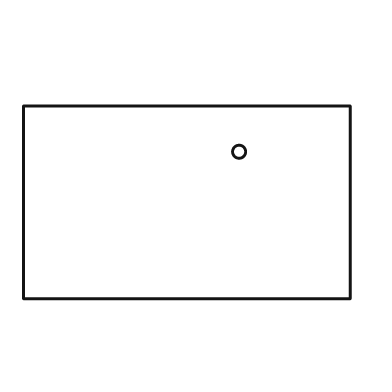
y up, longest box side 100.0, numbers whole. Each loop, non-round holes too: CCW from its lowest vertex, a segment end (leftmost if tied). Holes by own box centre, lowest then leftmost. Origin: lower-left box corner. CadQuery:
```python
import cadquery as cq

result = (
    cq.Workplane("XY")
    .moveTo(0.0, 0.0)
    .lineTo(100.0, 0.0)
    .lineTo(100.0, 59.0)
    .lineTo(0.0, 59.0)
    .close()
    .moveTo(66.0, 45.0)
    .circle(2.0)
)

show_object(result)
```